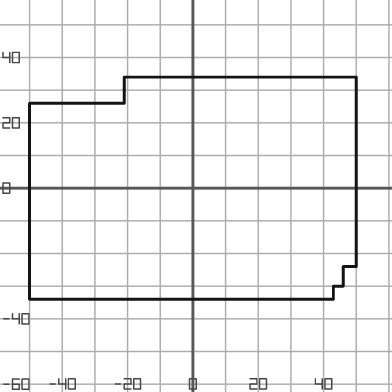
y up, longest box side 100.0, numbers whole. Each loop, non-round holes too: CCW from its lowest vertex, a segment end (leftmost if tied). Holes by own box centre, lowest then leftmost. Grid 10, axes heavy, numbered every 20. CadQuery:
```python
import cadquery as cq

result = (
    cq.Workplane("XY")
    .moveTo(-50.0, -34.0)
    .lineTo(43.0, -34.0)
    .lineTo(43.0, -30.0)
    .lineTo(46.0, -30.0)
    .lineTo(46.0, -24.0)
    .lineTo(50.0, -24.0)
    .lineTo(50.0, 34.0)
    .lineTo(-21.0, 34.0)
    .lineTo(-21.0, 26.0)
    .lineTo(-50.0, 26.0)
    .close()
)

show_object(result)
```